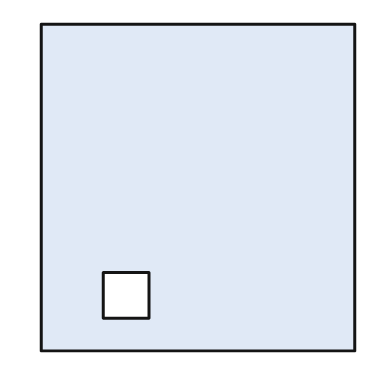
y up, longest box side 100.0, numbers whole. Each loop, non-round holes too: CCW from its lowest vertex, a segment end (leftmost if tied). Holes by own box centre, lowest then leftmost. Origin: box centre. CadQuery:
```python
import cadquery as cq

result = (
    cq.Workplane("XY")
    .moveTo(-48.0, -50.0)
    .lineTo(48.0, -50.0)
    .lineTo(48.0, 50.0)
    .lineTo(-48.0, 50.0)
    .close()
    .moveTo(-29.0, -40.0)
    .lineTo(-15.0, -40.0)
    .lineTo(-15.0, -26.0)
    .lineTo(-29.0, -26.0)
    .close()
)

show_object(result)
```